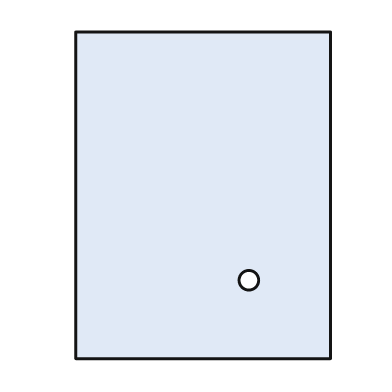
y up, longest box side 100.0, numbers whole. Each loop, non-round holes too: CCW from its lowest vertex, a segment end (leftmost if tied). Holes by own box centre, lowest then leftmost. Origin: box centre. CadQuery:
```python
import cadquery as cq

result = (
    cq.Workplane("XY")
    .moveTo(-39.0, -50.0)
    .lineTo(39.0, -50.0)
    .lineTo(39.0, 50.0)
    .lineTo(-39.0, 50.0)
    .close()
    .moveTo(14.0, -26.0)
    .circle(3.0)
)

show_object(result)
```